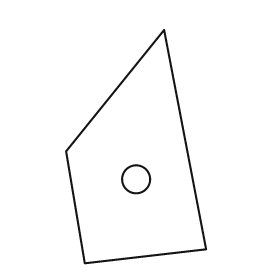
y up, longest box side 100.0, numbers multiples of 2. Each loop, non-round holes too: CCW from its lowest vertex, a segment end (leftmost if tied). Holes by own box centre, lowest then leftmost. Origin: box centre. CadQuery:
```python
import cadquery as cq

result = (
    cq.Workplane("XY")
    .moveTo(-22.0, -50.0)
    .lineTo(30.0, -44.0)
    .lineTo(12.0, 50.0)
    .lineTo(-30.0, -2.0)
    .close()
    .moveTo(0.0, -14.0)
    .circle(6.0)
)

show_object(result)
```